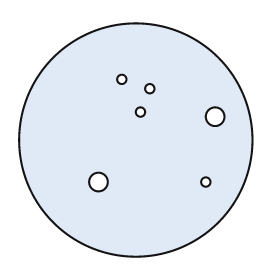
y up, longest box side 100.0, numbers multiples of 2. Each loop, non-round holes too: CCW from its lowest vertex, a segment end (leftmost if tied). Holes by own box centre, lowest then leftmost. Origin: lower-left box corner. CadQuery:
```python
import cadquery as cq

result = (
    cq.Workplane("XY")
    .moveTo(50.0, 50.0)
    .circle(50.0)
    .moveTo(34.0, 32.0)
    .circle(4.0)
    .moveTo(80.0, 32.0)
    .circle(2.0)
    .moveTo(84.0, 60.0)
    .circle(4.0)
    .moveTo(52.0, 62.0)
    .circle(2.0)
    .moveTo(56.0, 72.0)
    .circle(2.0)
    .moveTo(44.0, 76.0)
    .circle(2.0)
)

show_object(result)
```